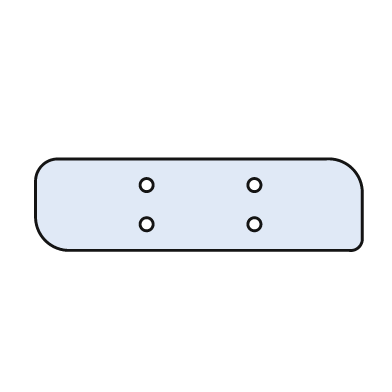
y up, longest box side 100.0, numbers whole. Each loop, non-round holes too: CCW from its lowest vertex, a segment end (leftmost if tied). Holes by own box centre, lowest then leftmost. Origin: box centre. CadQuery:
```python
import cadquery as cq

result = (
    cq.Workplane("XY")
    .moveTo(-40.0, -14.0)
    .lineTo(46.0, -14.0)
    .threePointArc((49.0, -13.0), (50.0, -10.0))
    .lineTo(50.0, 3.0)
    .threePointArc((47.0, 11.0), (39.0, 14.0))
    .lineTo(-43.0, 14.0)
    .threePointArc((-48.0, 12.0), (-50.0, 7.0))
    .lineTo(-50.0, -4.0)
    .threePointArc((-47.0, -11.0), (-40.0, -14.0))
    .close()
    .moveTo(-16.0, -6.0)
    .circle(2.0)
    .moveTo(17.0, -6.0)
    .circle(2.0)
    .moveTo(-16.0, 6.0)
    .circle(2.0)
    .moveTo(17.0, 6.0)
    .circle(2.0)
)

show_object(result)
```